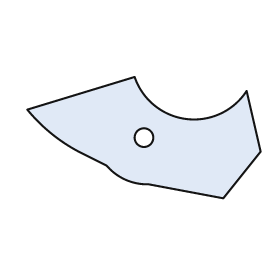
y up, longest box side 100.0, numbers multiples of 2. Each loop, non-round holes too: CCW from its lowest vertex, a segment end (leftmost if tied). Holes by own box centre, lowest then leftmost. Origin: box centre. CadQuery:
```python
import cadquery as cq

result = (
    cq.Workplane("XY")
    .moveTo(34.0, -26.0)
    .lineTo(50.0, -6.0)
    .lineTo(44.0, 20.0)
    .threePointArc((18.0, 8.0), (-4.0, 26.0))
    .lineTo(-50.0, 12.0)
    .threePointArc((-40.0, 2.0), (-28.0, -6.0))
    .lineTo(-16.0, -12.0)
    .threePointArc((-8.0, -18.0), (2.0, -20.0))
    .close()
    .moveTo(0.0, 0.0)
    .circle(4.0)
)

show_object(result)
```